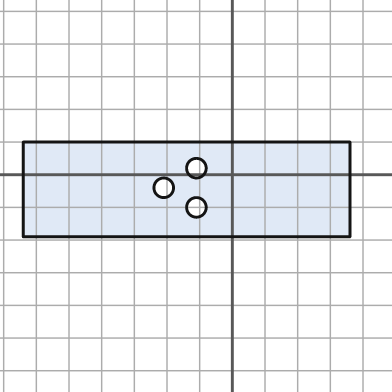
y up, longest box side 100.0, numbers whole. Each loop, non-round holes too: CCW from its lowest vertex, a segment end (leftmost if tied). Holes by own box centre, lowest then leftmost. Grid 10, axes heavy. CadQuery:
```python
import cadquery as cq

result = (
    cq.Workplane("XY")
    .moveTo(-64.0, -19.0)
    .lineTo(36.0, -19.0)
    .lineTo(36.0, 10.0)
    .lineTo(-64.0, 10.0)
    .close()
    .moveTo(-11.0, -10.0)
    .circle(3.0)
    .moveTo(-21.0, -4.0)
    .circle(3.0)
    .moveTo(-11.0, 2.0)
    .circle(3.0)
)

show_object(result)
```